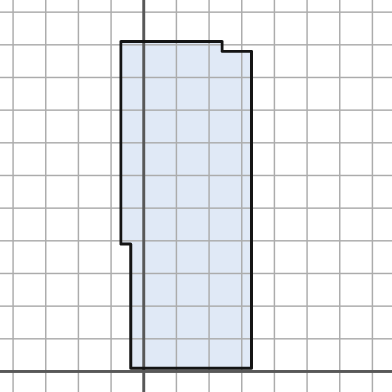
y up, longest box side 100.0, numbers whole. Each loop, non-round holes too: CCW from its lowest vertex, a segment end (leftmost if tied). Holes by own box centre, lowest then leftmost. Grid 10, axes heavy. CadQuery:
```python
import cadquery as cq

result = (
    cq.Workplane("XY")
    .moveTo(-4.0, 1.0)
    .lineTo(33.0, 1.0)
    .lineTo(33.0, 98.0)
    .lineTo(24.0, 98.0)
    .lineTo(24.0, 101.0)
    .lineTo(-7.0, 101.0)
    .lineTo(-7.0, 39.0)
    .lineTo(-4.0, 39.0)
    .close()
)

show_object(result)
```